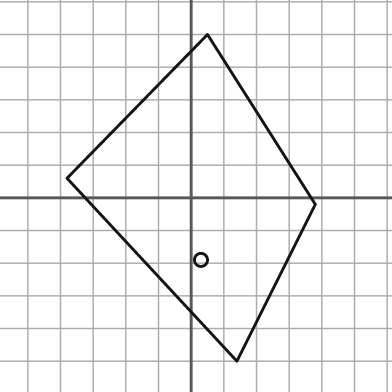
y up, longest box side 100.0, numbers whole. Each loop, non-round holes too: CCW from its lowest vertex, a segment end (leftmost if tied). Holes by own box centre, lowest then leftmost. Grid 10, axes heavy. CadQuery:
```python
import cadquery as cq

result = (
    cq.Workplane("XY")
    .moveTo(14.0, -50.0)
    .lineTo(38.0, -2.0)
    .lineTo(5.0, 50.0)
    .lineTo(-38.0, 6.0)
    .close()
    .moveTo(3.0, -19.0)
    .circle(2.0)
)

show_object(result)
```